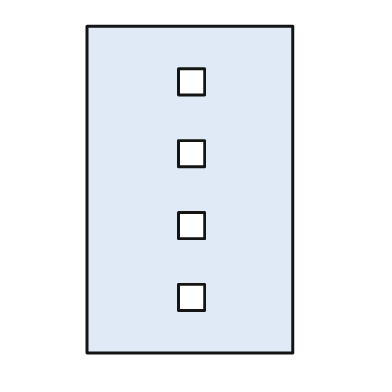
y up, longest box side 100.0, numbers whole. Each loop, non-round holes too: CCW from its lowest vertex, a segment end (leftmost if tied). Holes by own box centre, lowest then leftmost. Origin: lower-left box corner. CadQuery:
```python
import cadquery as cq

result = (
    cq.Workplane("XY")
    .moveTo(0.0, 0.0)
    .lineTo(63.0, 0.0)
    .lineTo(63.0, 100.0)
    .lineTo(0.0, 100.0)
    .close()
    .moveTo(28.0, 13.0)
    .lineTo(36.0, 13.0)
    .lineTo(36.0, 21.0)
    .lineTo(28.0, 21.0)
    .close()
    .moveTo(28.0, 35.0)
    .lineTo(36.0, 35.0)
    .lineTo(36.0, 43.0)
    .lineTo(28.0, 43.0)
    .close()
    .moveTo(28.0, 57.0)
    .lineTo(36.0, 57.0)
    .lineTo(36.0, 65.0)
    .lineTo(28.0, 65.0)
    .close()
    .moveTo(28.0, 79.0)
    .lineTo(36.0, 79.0)
    .lineTo(36.0, 87.0)
    .lineTo(28.0, 87.0)
    .close()
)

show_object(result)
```